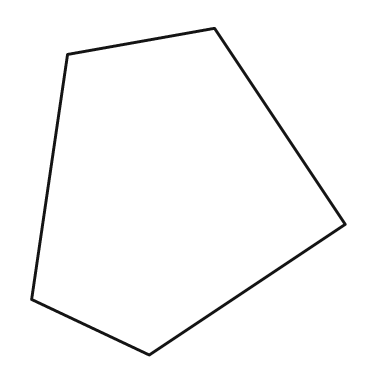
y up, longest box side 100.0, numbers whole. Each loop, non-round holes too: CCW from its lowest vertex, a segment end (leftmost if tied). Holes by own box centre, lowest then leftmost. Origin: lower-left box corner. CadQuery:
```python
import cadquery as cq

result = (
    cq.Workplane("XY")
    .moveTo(36.0, 0.0)
    .lineTo(96.0, 40.0)
    .lineTo(56.0, 100.0)
    .lineTo(11.0, 92.0)
    .lineTo(0.0, 17.0)
    .close()
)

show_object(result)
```